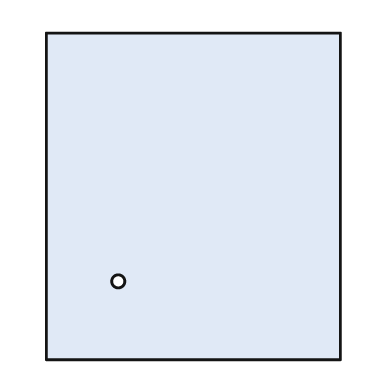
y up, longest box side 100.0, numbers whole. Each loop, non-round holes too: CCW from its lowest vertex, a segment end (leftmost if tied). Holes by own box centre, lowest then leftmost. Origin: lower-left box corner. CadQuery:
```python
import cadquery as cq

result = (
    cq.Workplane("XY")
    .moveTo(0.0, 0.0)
    .lineTo(90.0, 0.0)
    .lineTo(90.0, 100.0)
    .lineTo(0.0, 100.0)
    .close()
    .moveTo(22.0, 24.0)
    .circle(2.0)
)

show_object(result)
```